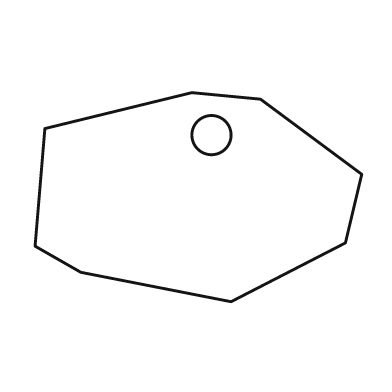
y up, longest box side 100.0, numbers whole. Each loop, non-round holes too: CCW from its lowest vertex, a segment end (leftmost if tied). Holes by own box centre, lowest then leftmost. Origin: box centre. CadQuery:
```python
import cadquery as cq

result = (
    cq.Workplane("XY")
    .moveTo(10.0, -32.0)
    .lineTo(45.0, -14.0)
    .lineTo(50.0, 7.0)
    .lineTo(19.0, 30.0)
    .lineTo(-2.0, 32.0)
    .lineTo(-47.0, 21.0)
    .lineTo(-50.0, -15.0)
    .lineTo(-36.0, -23.0)
    .close()
    .moveTo(4.0, 19.0)
    .circle(6.0)
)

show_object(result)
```